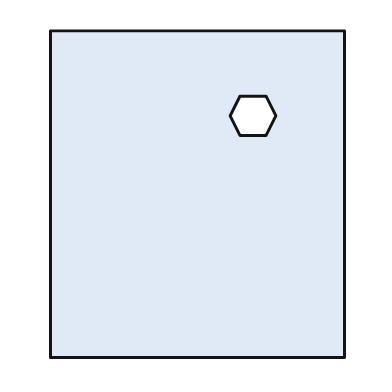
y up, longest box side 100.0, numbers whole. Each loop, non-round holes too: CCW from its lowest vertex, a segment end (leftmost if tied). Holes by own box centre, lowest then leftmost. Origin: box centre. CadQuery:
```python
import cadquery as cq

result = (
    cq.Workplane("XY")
    .moveTo(-45.0, -50.0)
    .lineTo(45.0, -50.0)
    .lineTo(45.0, 50.0)
    .lineTo(-45.0, 50.0)
    .close()
    .moveTo(13.0, 18.0)
    .lineTo(21.0, 18.0)
    .lineTo(24.0, 24.0)
    .lineTo(21.0, 30.0)
    .lineTo(13.0, 30.0)
    .lineTo(10.0, 24.0)
    .close()
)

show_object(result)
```